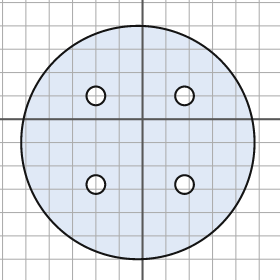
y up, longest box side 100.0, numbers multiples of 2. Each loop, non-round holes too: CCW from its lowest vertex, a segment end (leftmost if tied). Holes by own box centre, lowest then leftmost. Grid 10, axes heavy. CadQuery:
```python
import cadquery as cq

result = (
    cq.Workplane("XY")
    .moveTo(-2.0, -10.0)
    .circle(50.0)
    .moveTo(-20.0, -28.0)
    .circle(4.0)
    .moveTo(18.0, -28.0)
    .circle(4.0)
    .moveTo(-20.0, 10.0)
    .circle(4.0)
    .moveTo(18.0, 10.0)
    .circle(4.0)
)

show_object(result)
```